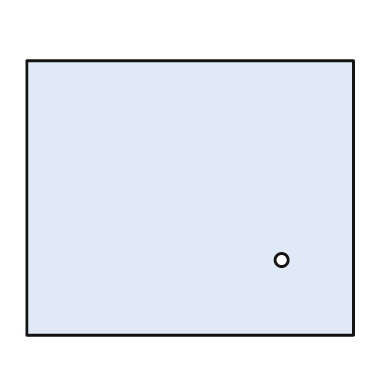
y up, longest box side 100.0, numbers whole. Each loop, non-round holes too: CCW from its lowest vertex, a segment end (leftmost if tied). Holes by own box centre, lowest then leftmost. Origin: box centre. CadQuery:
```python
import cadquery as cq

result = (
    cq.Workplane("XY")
    .moveTo(-50.0, -42.0)
    .lineTo(50.0, -42.0)
    .lineTo(50.0, 42.0)
    .lineTo(-50.0, 42.0)
    .close()
    .moveTo(28.0, -19.0)
    .circle(2.0)
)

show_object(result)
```